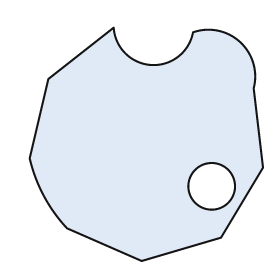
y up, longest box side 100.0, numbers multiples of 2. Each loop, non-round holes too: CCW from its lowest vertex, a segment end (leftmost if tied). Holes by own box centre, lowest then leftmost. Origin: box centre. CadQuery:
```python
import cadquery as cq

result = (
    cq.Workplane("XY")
    .moveTo(-2.0, -50.0)
    .lineTo(32.0, -40.0)
    .lineTo(50.0, -10.0)
    .lineTo(46.0, 24.0)
    .threePointArc((40.0, 44.0), (20.0, 48.0))
    .threePointArc((2.0, 34.0), (-14.0, 50.0))
    .lineTo(-42.0, 28.0)
    .lineTo(-50.0, -6.0)
    .threePointArc((-44.0, -22.0), (-34.0, -36.0))
    .close()
    .moveTo(28.0, -18.0)
    .circle(10.0)
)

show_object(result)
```